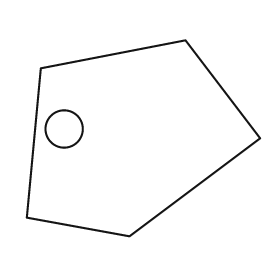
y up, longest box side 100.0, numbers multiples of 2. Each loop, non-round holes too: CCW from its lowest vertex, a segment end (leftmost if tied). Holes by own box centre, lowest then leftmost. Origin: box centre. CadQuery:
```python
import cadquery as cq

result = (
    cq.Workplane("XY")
    .moveTo(-6.0, -42.0)
    .lineTo(50.0, 0.0)
    .lineTo(18.0, 42.0)
    .lineTo(-44.0, 30.0)
    .lineTo(-50.0, -34.0)
    .close()
    .moveTo(-34.0, 4.0)
    .circle(8.0)
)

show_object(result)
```